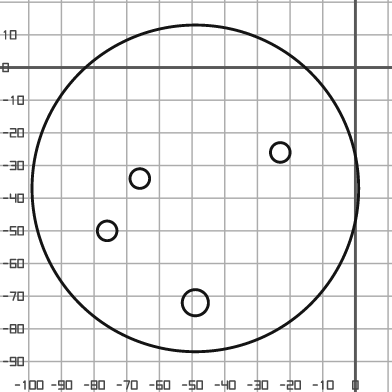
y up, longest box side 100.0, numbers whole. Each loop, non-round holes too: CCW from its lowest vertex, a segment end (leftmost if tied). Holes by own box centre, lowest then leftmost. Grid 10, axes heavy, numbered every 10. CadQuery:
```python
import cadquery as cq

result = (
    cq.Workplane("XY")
    .moveTo(-49.0, -37.0)
    .circle(50.0)
    .moveTo(-49.0, -72.0)
    .circle(4.0)
    .moveTo(-76.0, -50.0)
    .circle(3.0)
    .moveTo(-66.0, -34.0)
    .circle(3.0)
    .moveTo(-23.0, -26.0)
    .circle(3.0)
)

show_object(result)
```